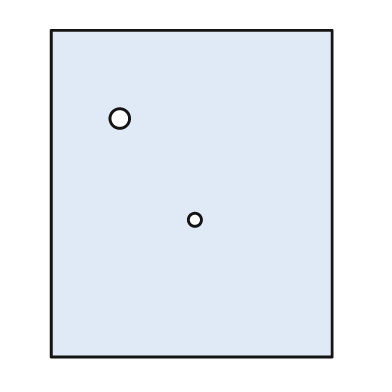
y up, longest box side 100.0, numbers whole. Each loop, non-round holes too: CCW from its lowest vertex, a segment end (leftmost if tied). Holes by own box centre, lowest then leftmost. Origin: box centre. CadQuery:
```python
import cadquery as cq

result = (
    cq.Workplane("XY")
    .moveTo(-43.0, -50.0)
    .lineTo(43.0, -50.0)
    .lineTo(43.0, 50.0)
    .lineTo(-43.0, 50.0)
    .close()
    .moveTo(1.0, -8.0)
    .circle(2.0)
    .moveTo(-22.0, 23.0)
    .circle(3.0)
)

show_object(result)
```